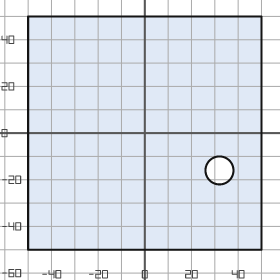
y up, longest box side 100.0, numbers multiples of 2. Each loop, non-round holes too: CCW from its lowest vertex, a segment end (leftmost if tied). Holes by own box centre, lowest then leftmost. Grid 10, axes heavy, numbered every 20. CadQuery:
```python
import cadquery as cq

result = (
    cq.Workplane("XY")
    .moveTo(-50.0, -50.0)
    .lineTo(50.0, -50.0)
    .lineTo(50.0, 50.0)
    .lineTo(-50.0, 50.0)
    .close()
    .moveTo(32.0, -16.0)
    .circle(6.0)
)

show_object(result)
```